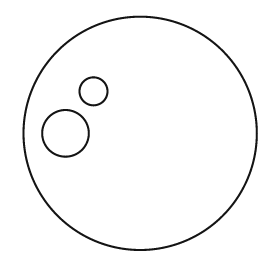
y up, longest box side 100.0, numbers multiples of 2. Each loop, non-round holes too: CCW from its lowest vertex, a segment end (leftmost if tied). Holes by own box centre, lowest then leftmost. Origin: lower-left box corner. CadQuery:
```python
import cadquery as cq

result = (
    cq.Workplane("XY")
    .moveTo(50.0, 50.0)
    .circle(50.0)
    .moveTo(18.0, 50.0)
    .circle(10.0)
    .moveTo(30.0, 68.0)
    .circle(6.0)
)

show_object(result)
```